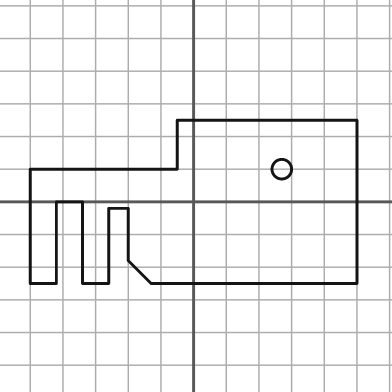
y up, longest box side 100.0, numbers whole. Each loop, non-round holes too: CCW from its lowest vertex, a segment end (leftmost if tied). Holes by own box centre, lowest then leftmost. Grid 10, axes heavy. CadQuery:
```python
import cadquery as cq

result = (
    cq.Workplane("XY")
    .moveTo(-50.0, -25.0)
    .lineTo(-42.0, -25.0)
    .lineTo(-42.0, 0.0)
    .lineTo(-34.0, 0.0)
    .lineTo(-34.0, -25.0)
    .lineTo(-26.0, -25.0)
    .lineTo(-26.0, -2.0)
    .lineTo(-20.0, -2.0)
    .lineTo(-20.0, -18.0)
    .lineTo(-13.0, -25.0)
    .lineTo(50.0, -25.0)
    .lineTo(50.0, 25.0)
    .lineTo(-5.0, 25.0)
    .lineTo(-5.0, 10.0)
    .lineTo(-50.0, 10.0)
    .close()
    .moveTo(27.0, 10.0)
    .circle(3.0)
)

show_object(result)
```